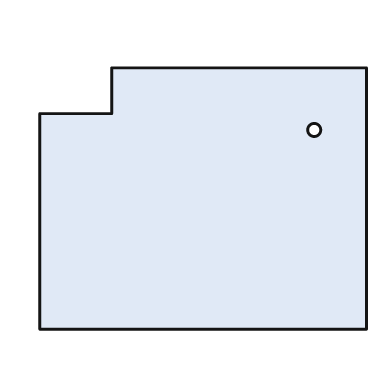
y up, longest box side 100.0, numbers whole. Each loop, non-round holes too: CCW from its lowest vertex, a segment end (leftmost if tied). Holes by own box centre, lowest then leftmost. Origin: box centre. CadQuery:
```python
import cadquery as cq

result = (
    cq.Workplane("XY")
    .moveTo(-50.0, -40.0)
    .lineTo(50.0, -40.0)
    .lineTo(50.0, 40.0)
    .lineTo(-28.0, 40.0)
    .lineTo(-28.0, 26.0)
    .lineTo(-50.0, 26.0)
    .close()
    .moveTo(34.0, 21.0)
    .circle(2.0)
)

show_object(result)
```